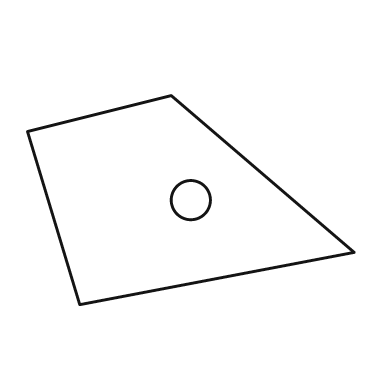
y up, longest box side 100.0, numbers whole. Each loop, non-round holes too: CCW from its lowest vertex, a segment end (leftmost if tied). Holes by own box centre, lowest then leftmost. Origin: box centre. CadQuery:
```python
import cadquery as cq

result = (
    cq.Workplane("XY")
    .moveTo(-34.0, -32.0)
    .lineTo(50.0, -16.0)
    .lineTo(-6.0, 32.0)
    .lineTo(-50.0, 21.0)
    .close()
    .moveTo(0.0, 0.0)
    .circle(6.0)
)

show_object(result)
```